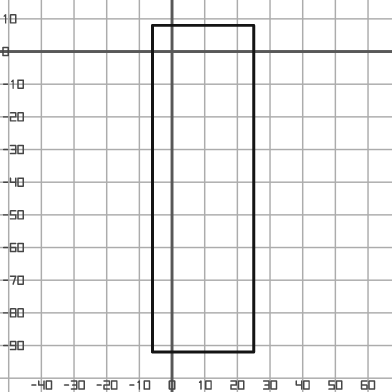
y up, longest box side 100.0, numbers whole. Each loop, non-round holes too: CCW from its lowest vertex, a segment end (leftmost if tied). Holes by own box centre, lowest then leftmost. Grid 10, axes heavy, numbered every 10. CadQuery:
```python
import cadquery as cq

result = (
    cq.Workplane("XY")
    .moveTo(-6.0, -92.0)
    .lineTo(25.0, -92.0)
    .lineTo(25.0, 8.0)
    .lineTo(-6.0, 8.0)
    .close()
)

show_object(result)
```